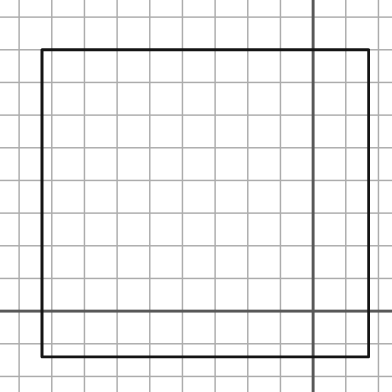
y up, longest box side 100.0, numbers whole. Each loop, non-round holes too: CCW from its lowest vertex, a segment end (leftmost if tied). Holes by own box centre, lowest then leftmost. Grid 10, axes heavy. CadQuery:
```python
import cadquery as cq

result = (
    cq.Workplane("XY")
    .moveTo(-83.0, -14.0)
    .lineTo(17.0, -14.0)
    .lineTo(17.0, 80.0)
    .lineTo(-83.0, 80.0)
    .close()
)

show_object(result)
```